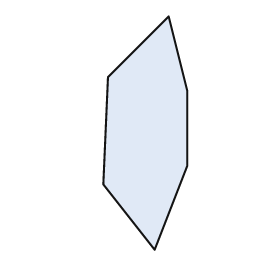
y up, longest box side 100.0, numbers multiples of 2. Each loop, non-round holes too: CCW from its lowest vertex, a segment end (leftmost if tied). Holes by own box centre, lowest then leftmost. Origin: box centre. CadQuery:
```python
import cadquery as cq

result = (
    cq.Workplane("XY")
    .moveTo(4.0, -50.0)
    .lineTo(18.0, -14.0)
    .lineTo(18.0, 18.0)
    .lineTo(10.0, 50.0)
    .lineTo(-16.0, 24.0)
    .lineTo(-18.0, -22.0)
    .close()
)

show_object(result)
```